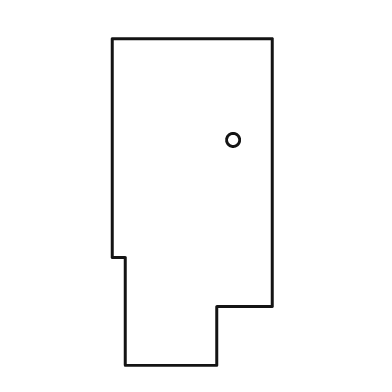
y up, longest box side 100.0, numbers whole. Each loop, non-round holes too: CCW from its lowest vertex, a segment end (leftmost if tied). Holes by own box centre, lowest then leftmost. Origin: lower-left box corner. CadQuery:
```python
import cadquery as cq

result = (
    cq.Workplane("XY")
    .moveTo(4.0, 0.0)
    .lineTo(32.0, 0.0)
    .lineTo(32.0, 18.0)
    .lineTo(49.0, 18.0)
    .lineTo(49.0, 100.0)
    .lineTo(0.0, 100.0)
    .lineTo(0.0, 33.0)
    .lineTo(4.0, 33.0)
    .close()
    .moveTo(37.0, 69.0)
    .circle(2.0)
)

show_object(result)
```